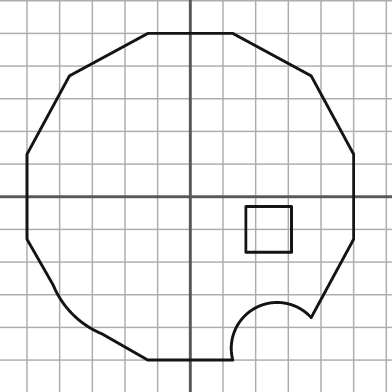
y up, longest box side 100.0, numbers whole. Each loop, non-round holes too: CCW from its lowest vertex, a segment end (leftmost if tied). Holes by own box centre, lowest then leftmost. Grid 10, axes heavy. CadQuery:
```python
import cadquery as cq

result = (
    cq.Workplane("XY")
    .moveTo(-13.0, -50.0)
    .lineTo(13.0, -50.0)
    .threePointArc((20.0, -34.0), (37.0, -37.0))
    .lineTo(50.0, -13.0)
    .lineTo(50.0, 13.0)
    .lineTo(37.0, 37.0)
    .lineTo(13.0, 50.0)
    .lineTo(-13.0, 50.0)
    .lineTo(-37.0, 37.0)
    .lineTo(-50.0, 13.0)
    .lineTo(-50.0, -13.0)
    .lineTo(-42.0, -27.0)
    .threePointArc((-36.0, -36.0), (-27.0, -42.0))
    .close()
    .moveTo(17.0, -17.0)
    .lineTo(31.0, -17.0)
    .lineTo(31.0, -3.0)
    .lineTo(17.0, -3.0)
    .close()
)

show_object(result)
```